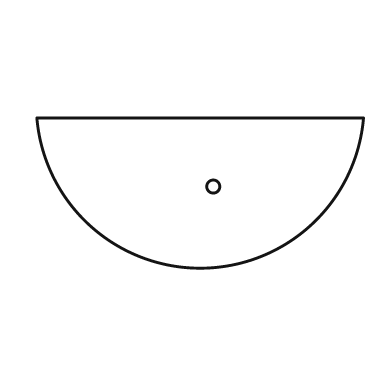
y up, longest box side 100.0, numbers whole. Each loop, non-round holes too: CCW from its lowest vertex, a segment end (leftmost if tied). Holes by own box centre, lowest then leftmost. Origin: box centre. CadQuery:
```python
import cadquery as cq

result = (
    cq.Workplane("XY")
    .moveTo(-50.0, 23.0)
    .threePointArc((0.0, -23.0), (50.0, 23.0))
    .close()
    .moveTo(4.0, 2.0)
    .circle(2.0)
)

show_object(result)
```